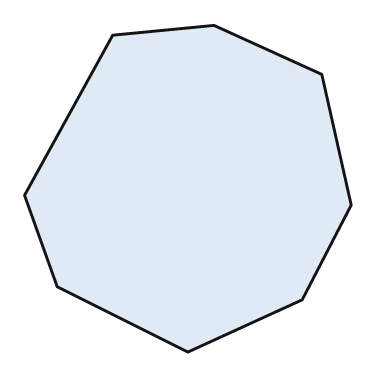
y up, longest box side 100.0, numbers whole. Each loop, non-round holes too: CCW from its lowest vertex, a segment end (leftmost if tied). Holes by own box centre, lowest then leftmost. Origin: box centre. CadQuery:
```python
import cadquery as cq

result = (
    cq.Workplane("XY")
    .moveTo(0.0, -50.0)
    .lineTo(35.0, -34.0)
    .lineTo(50.0, -5.0)
    .lineTo(41.0, 35.0)
    .lineTo(8.0, 50.0)
    .lineTo(-23.0, 47.0)
    .lineTo(-50.0, -2.0)
    .lineTo(-40.0, -30.0)
    .close()
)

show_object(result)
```